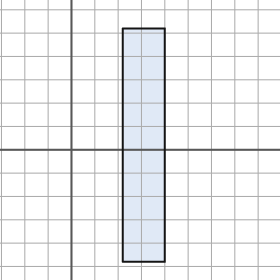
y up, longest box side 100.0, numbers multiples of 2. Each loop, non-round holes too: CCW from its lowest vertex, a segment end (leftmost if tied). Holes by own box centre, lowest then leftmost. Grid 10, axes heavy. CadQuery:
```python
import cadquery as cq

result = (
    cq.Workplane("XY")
    .moveTo(22.0, -48.0)
    .lineTo(40.0, -48.0)
    .lineTo(40.0, 52.0)
    .lineTo(22.0, 52.0)
    .close()
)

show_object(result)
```